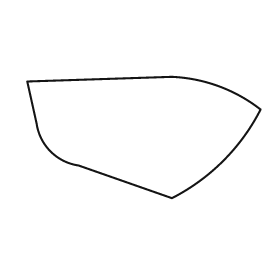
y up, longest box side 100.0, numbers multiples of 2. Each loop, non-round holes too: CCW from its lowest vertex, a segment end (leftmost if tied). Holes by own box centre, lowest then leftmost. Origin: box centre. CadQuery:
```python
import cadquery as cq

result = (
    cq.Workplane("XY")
    .moveTo(12.0, -26.0)
    .threePointArc((34.0, -10.0), (50.0, 12.0))
    .threePointArc((32.0, 22.0), (12.0, 26.0))
    .lineTo(-50.0, 24.0)
    .lineTo(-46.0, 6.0)
    .threePointArc((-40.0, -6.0), (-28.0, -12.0))
    .close()
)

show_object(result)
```